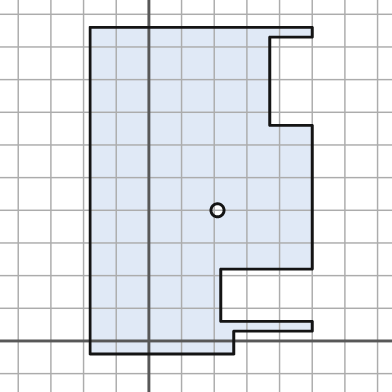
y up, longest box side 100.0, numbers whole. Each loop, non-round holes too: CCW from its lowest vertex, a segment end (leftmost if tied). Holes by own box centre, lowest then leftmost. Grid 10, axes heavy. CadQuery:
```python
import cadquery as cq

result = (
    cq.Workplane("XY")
    .moveTo(-18.0, -4.0)
    .lineTo(26.0, -4.0)
    .lineTo(26.0, 3.0)
    .lineTo(50.0, 3.0)
    .lineTo(50.0, 6.0)
    .lineTo(22.0, 6.0)
    .lineTo(22.0, 22.0)
    .lineTo(50.0, 22.0)
    .lineTo(50.0, 66.0)
    .lineTo(37.0, 66.0)
    .lineTo(37.0, 93.0)
    .lineTo(50.0, 93.0)
    .lineTo(50.0, 96.0)
    .lineTo(-18.0, 96.0)
    .close()
    .moveTo(21.0, 40.0)
    .circle(2.0)
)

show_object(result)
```